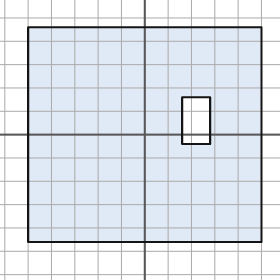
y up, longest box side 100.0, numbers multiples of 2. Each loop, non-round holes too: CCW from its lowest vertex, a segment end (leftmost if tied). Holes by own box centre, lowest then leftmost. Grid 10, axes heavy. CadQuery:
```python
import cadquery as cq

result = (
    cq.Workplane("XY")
    .moveTo(-50.0, -46.0)
    .lineTo(50.0, -46.0)
    .lineTo(50.0, 46.0)
    .lineTo(-50.0, 46.0)
    .close()
    .moveTo(16.0, -4.0)
    .lineTo(28.0, -4.0)
    .lineTo(28.0, 16.0)
    .lineTo(16.0, 16.0)
    .close()
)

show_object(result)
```